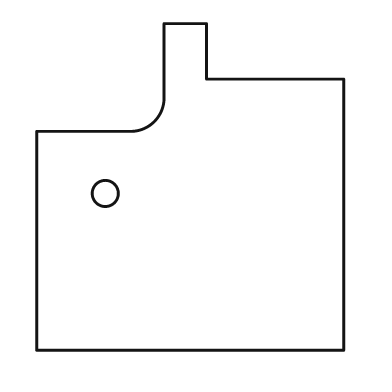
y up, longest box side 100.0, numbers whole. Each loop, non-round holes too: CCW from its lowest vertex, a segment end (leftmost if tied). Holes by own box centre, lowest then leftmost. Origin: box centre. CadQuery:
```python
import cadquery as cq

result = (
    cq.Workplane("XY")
    .moveTo(-47.0, -50.0)
    .lineTo(47.0, -50.0)
    .lineTo(47.0, 33.0)
    .lineTo(5.0, 33.0)
    .lineTo(5.0, 50.0)
    .lineTo(-8.0, 50.0)
    .lineTo(-8.0, 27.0)
    .threePointArc((-11.0, 20.0), (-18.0, 17.0))
    .lineTo(-47.0, 17.0)
    .close()
    .moveTo(-26.0, -2.0)
    .circle(4.0)
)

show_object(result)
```